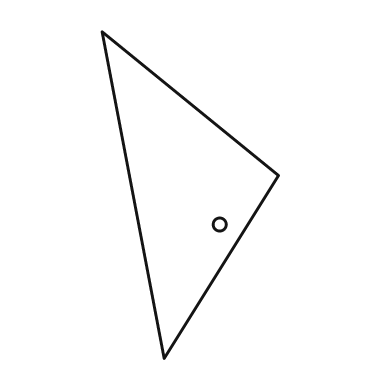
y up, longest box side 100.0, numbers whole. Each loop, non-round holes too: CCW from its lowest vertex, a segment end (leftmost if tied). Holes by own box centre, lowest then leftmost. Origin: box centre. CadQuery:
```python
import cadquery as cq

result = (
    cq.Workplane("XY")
    .moveTo(-8.0, -50.0)
    .lineTo(27.0, 6.0)
    .lineTo(-27.0, 50.0)
    .close()
    .moveTo(9.0, -9.0)
    .circle(2.0)
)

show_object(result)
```